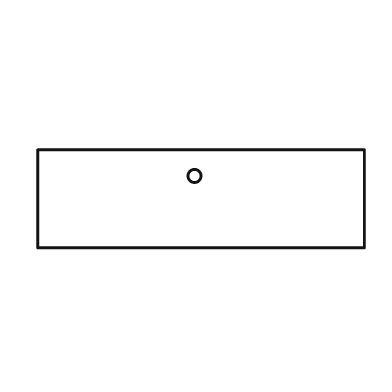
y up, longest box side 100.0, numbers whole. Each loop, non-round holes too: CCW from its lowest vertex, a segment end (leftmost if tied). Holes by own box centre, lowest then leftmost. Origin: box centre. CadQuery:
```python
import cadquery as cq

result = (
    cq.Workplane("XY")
    .moveTo(-50.0, -15.0)
    .lineTo(50.0, -15.0)
    .lineTo(50.0, 15.0)
    .lineTo(-50.0, 15.0)
    .close()
    .moveTo(-2.0, 7.0)
    .circle(2.0)
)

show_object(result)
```